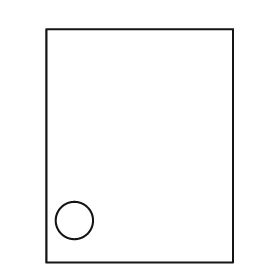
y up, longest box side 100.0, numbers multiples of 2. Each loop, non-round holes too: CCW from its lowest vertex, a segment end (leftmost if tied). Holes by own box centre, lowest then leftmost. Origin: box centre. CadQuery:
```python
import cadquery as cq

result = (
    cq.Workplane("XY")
    .moveTo(-40.0, -50.0)
    .lineTo(40.0, -50.0)
    .lineTo(40.0, 50.0)
    .lineTo(-40.0, 50.0)
    .close()
    .moveTo(-28.0, -32.0)
    .circle(8.0)
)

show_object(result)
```